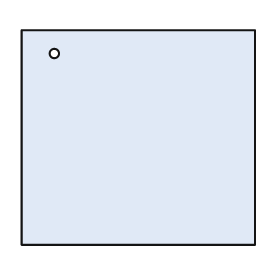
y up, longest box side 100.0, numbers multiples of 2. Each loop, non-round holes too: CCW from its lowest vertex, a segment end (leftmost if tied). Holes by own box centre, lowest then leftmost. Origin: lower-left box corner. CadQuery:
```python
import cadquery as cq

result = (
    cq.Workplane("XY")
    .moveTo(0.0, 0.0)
    .lineTo(100.0, 0.0)
    .lineTo(100.0, 92.0)
    .lineTo(0.0, 92.0)
    .close()
    .moveTo(14.0, 82.0)
    .circle(2.0)
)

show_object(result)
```